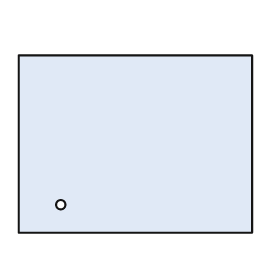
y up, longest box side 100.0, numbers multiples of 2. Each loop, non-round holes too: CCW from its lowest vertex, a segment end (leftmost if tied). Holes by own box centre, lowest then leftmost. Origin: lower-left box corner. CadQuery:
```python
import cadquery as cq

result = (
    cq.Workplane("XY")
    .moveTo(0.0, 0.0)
    .lineTo(100.0, 0.0)
    .lineTo(100.0, 76.0)
    .lineTo(0.0, 76.0)
    .close()
    .moveTo(18.0, 12.0)
    .circle(2.0)
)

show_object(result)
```